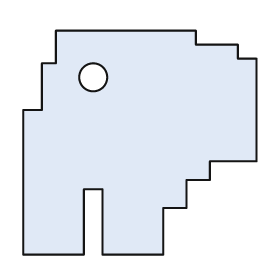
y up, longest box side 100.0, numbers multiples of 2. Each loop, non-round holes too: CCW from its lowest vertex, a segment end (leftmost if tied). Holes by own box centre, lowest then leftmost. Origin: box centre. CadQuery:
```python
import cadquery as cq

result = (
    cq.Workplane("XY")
    .moveTo(-50.0, -48.0)
    .lineTo(-24.0, -48.0)
    .lineTo(-24.0, -20.0)
    .lineTo(-16.0, -20.0)
    .lineTo(-16.0, -48.0)
    .lineTo(10.0, -48.0)
    .lineTo(10.0, -28.0)
    .lineTo(20.0, -28.0)
    .lineTo(20.0, -16.0)
    .lineTo(30.0, -16.0)
    .lineTo(30.0, -8.0)
    .lineTo(50.0, -8.0)
    .lineTo(50.0, 36.0)
    .lineTo(42.0, 36.0)
    .lineTo(42.0, 42.0)
    .lineTo(24.0, 42.0)
    .lineTo(24.0, 48.0)
    .lineTo(-36.0, 48.0)
    .lineTo(-36.0, 34.0)
    .lineTo(-42.0, 34.0)
    .lineTo(-42.0, 14.0)
    .lineTo(-50.0, 14.0)
    .close()
    .moveTo(-20.0, 28.0)
    .circle(6.0)
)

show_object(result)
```